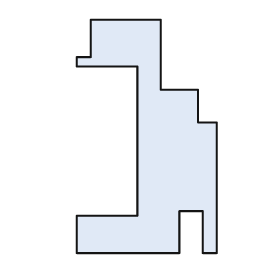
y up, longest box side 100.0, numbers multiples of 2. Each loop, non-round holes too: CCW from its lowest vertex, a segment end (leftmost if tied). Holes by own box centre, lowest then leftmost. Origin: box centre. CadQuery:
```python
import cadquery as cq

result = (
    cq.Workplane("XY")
    .moveTo(-30.0, -50.0)
    .lineTo(14.0, -50.0)
    .lineTo(14.0, -32.0)
    .lineTo(24.0, -32.0)
    .lineTo(24.0, -50.0)
    .lineTo(30.0, -50.0)
    .lineTo(30.0, 6.0)
    .lineTo(22.0, 6.0)
    .lineTo(22.0, 20.0)
    .lineTo(6.0, 20.0)
    .lineTo(6.0, 50.0)
    .lineTo(-24.0, 50.0)
    .lineTo(-24.0, 34.0)
    .lineTo(-30.0, 34.0)
    .lineTo(-30.0, 30.0)
    .lineTo(-4.0, 30.0)
    .lineTo(-4.0, -34.0)
    .lineTo(-30.0, -34.0)
    .close()
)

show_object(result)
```